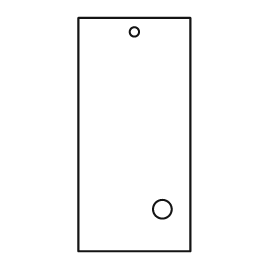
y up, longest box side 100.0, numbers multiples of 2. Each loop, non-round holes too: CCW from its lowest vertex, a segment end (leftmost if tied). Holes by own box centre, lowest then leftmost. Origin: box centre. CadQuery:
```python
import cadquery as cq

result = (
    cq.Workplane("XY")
    .moveTo(-24.0, -50.0)
    .lineTo(24.0, -50.0)
    .lineTo(24.0, 50.0)
    .lineTo(-24.0, 50.0)
    .close()
    .moveTo(12.0, -32.0)
    .circle(4.0)
    .moveTo(0.0, 44.0)
    .circle(2.0)
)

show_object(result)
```